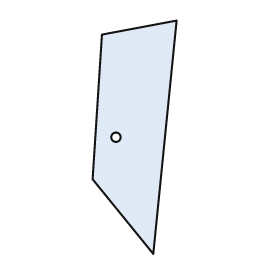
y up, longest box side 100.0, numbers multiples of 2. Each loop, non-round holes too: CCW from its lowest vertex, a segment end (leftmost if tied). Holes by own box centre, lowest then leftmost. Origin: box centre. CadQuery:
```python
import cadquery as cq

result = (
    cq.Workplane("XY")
    .moveTo(8.0, -50.0)
    .lineTo(18.0, 50.0)
    .lineTo(-14.0, 44.0)
    .lineTo(-18.0, -18.0)
    .close()
    .moveTo(-8.0, 0.0)
    .circle(2.0)
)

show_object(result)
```